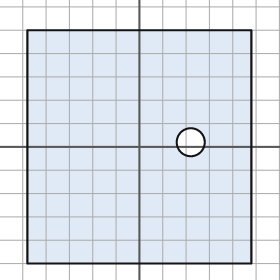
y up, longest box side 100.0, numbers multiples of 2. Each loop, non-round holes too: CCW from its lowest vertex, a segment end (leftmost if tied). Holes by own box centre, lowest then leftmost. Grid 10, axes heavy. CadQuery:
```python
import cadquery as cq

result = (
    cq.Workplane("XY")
    .moveTo(-48.0, -50.0)
    .lineTo(48.0, -50.0)
    .lineTo(48.0, 50.0)
    .lineTo(-48.0, 50.0)
    .close()
    .moveTo(22.0, 2.0)
    .circle(6.0)
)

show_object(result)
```